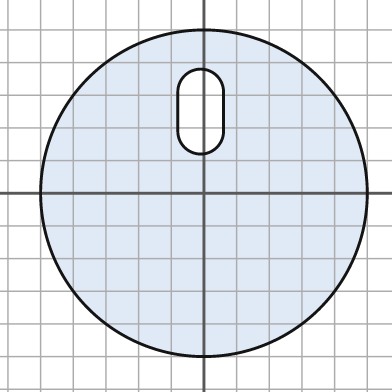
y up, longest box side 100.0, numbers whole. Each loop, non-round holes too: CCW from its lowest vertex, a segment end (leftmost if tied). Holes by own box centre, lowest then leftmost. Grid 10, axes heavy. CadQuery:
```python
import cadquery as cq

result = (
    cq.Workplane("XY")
    .moveTo(0.0, 0.0)
    .circle(50.0)
    .moveTo(-8.0, 19.0)
    .threePointArc((-1.0, 12.0), (6.0, 19.0))
    .lineTo(6.0, 31.0)
    .threePointArc((-1.0, 38.0), (-8.0, 31.0))
    .close()
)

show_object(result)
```